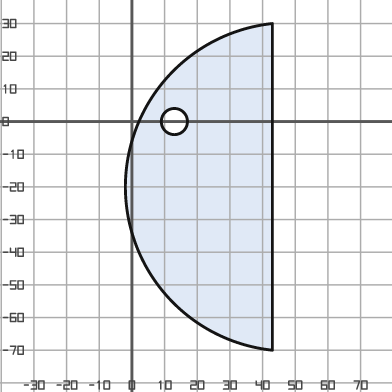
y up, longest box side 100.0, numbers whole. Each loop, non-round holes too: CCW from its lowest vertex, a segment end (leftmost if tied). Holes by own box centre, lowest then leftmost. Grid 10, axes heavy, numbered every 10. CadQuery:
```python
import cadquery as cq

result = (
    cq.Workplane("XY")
    .moveTo(43.0, -70.0)
    .lineTo(43.0, 30.0)
    .threePointArc((-2.0, -20.0), (43.0, -70.0))
    .close()
    .moveTo(13.0, 0.0)
    .circle(4.0)
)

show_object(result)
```